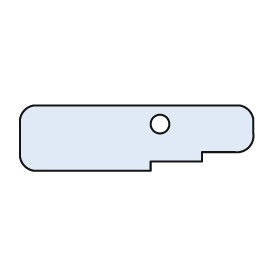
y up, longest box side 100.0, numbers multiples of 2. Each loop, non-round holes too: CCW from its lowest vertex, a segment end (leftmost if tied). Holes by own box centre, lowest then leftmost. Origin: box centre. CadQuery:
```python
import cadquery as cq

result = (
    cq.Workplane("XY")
    .moveTo(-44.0, -14.0)
    .lineTo(6.0, -14.0)
    .lineTo(6.0, -10.0)
    .lineTo(28.0, -10.0)
    .lineTo(28.0, -6.0)
    .lineTo(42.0, -6.0)
    .threePointArc((48.0, -4.0), (50.0, 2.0))
    .lineTo(50.0, 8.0)
    .threePointArc((48.0, 12.0), (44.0, 14.0))
    .lineTo(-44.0, 14.0)
    .threePointArc((-48.0, 12.0), (-50.0, 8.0))
    .lineTo(-50.0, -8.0)
    .threePointArc((-48.0, -12.0), (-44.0, -14.0))
    .close()
    .moveTo(10.0, 6.0)
    .circle(4.0)
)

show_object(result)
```